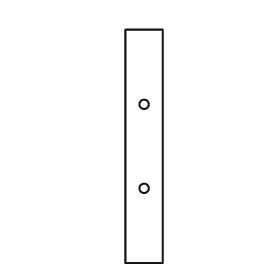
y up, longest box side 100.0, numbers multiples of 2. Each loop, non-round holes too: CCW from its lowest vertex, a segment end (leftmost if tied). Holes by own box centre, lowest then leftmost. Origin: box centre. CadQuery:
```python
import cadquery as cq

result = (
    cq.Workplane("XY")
    .moveTo(-8.0, -50.0)
    .lineTo(8.0, -50.0)
    .lineTo(8.0, 50.0)
    .lineTo(-8.0, 50.0)
    .close()
    .moveTo(0.0, -18.0)
    .circle(2.0)
    .moveTo(0.0, 18.0)
    .circle(2.0)
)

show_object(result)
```